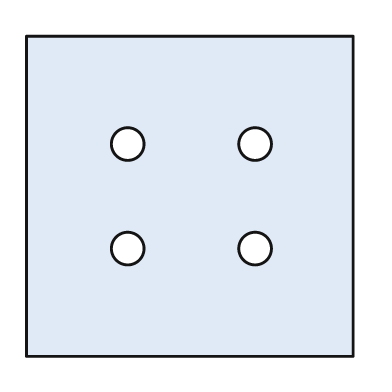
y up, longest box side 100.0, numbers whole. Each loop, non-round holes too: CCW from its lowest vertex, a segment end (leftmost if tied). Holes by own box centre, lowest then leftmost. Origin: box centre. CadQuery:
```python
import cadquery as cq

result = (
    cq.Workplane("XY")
    .moveTo(-50.0, -49.0)
    .lineTo(50.0, -49.0)
    .lineTo(50.0, 49.0)
    .lineTo(-50.0, 49.0)
    .close()
    .moveTo(-19.0, -16.0)
    .circle(5.0)
    .moveTo(20.0, -16.0)
    .circle(5.0)
    .moveTo(-19.0, 16.0)
    .circle(5.0)
    .moveTo(20.0, 16.0)
    .circle(5.0)
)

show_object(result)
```